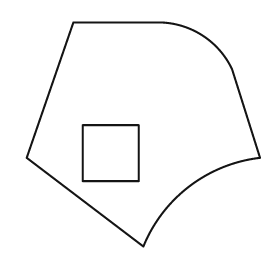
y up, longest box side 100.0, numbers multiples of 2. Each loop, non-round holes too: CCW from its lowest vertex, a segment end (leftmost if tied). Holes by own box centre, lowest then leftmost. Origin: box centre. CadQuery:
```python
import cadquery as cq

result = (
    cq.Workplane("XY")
    .moveTo(0.0, -48.0)
    .threePointArc((20.0, -22.0), (50.0, -10.0))
    .lineTo(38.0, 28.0)
    .threePointArc((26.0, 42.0), (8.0, 48.0))
    .lineTo(-30.0, 48.0)
    .lineTo(-50.0, -10.0)
    .close()
    .moveTo(-26.0, -20.0)
    .lineTo(-2.0, -20.0)
    .lineTo(-2.0, 4.0)
    .lineTo(-26.0, 4.0)
    .close()
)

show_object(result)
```